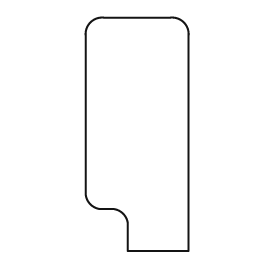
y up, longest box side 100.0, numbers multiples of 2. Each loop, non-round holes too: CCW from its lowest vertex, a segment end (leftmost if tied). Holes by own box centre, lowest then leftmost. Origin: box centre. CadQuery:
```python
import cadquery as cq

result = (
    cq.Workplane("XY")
    .moveTo(-4.0, -50.0)
    .lineTo(22.0, -50.0)
    .lineTo(22.0, 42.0)
    .threePointArc((20.0, 48.0), (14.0, 50.0))
    .lineTo(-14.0, 50.0)
    .threePointArc((-20.0, 48.0), (-22.0, 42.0))
    .lineTo(-22.0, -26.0)
    .threePointArc((-20.0, -30.0), (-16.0, -32.0))
    .lineTo(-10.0, -32.0)
    .threePointArc((-6.0, -34.0), (-4.0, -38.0))
    .close()
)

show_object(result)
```